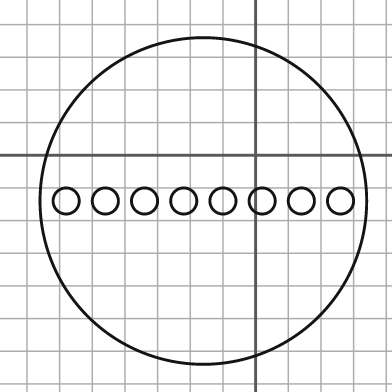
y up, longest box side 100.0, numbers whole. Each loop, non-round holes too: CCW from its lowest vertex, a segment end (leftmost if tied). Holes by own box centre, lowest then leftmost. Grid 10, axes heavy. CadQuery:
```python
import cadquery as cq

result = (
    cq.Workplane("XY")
    .moveTo(-16.0, -14.0)
    .circle(50.0)
    .moveTo(-58.0, -14.0)
    .circle(4.0)
    .moveTo(-46.0, -14.0)
    .circle(4.0)
    .moveTo(-34.0, -14.0)
    .circle(4.0)
    .moveTo(-22.0, -14.0)
    .circle(4.0)
    .moveTo(-10.0, -14.0)
    .circle(4.0)
    .moveTo(2.0, -14.0)
    .circle(4.0)
    .moveTo(14.0, -14.0)
    .circle(4.0)
    .moveTo(26.0, -14.0)
    .circle(4.0)
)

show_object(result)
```